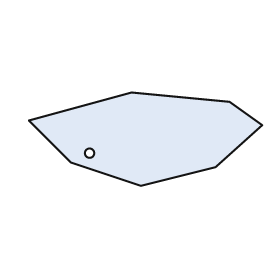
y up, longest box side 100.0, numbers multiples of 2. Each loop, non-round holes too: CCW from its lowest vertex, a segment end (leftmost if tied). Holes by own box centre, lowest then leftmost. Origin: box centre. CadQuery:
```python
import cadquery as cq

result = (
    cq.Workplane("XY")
    .moveTo(-2.0, -20.0)
    .lineTo(30.0, -12.0)
    .lineTo(50.0, 6.0)
    .lineTo(36.0, 16.0)
    .lineTo(-6.0, 20.0)
    .lineTo(-50.0, 8.0)
    .lineTo(-32.0, -10.0)
    .close()
    .moveTo(-24.0, -6.0)
    .circle(2.0)
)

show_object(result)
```